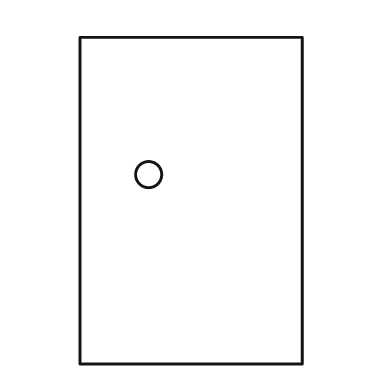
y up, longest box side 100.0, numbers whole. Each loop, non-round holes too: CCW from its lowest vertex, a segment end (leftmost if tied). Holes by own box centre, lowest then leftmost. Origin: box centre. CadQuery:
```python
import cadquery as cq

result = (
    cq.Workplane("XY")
    .moveTo(-34.0, -50.0)
    .lineTo(34.0, -50.0)
    .lineTo(34.0, 50.0)
    .lineTo(-34.0, 50.0)
    .close()
    .moveTo(-13.0, 8.0)
    .circle(4.0)
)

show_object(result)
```